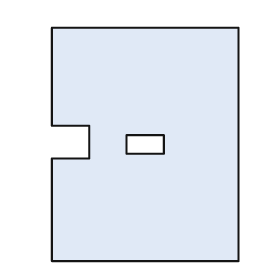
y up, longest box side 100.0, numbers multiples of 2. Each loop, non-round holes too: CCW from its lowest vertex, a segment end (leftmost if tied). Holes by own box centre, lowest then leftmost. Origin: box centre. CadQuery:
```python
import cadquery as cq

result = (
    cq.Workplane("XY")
    .moveTo(-40.0, -50.0)
    .lineTo(40.0, -50.0)
    .lineTo(40.0, 50.0)
    .lineTo(-40.0, 50.0)
    .lineTo(-40.0, 8.0)
    .lineTo(-24.0, 8.0)
    .lineTo(-24.0, -6.0)
    .lineTo(-40.0, -6.0)
    .close()
    .moveTo(-8.0, -4.0)
    .lineTo(8.0, -4.0)
    .lineTo(8.0, 4.0)
    .lineTo(-8.0, 4.0)
    .close()
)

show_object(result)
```